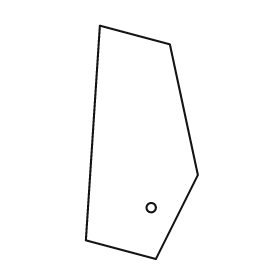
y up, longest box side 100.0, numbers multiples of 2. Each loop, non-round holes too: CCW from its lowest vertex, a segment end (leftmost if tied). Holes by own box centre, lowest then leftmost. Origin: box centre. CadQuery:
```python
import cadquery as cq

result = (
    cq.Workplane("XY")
    .moveTo(6.0, -50.0)
    .lineTo(24.0, -14.0)
    .lineTo(12.0, 42.0)
    .lineTo(-18.0, 50.0)
    .lineTo(-24.0, -42.0)
    .close()
    .moveTo(4.0, -28.0)
    .circle(2.0)
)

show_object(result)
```